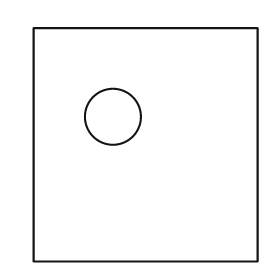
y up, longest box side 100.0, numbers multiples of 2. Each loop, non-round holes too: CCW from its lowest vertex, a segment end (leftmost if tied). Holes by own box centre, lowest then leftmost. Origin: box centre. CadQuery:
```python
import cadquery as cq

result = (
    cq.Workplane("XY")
    .moveTo(-48.0, -50.0)
    .lineTo(48.0, -50.0)
    .lineTo(48.0, 50.0)
    .lineTo(-48.0, 50.0)
    .close()
    .moveTo(-14.0, 12.0)
    .circle(12.0)
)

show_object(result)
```